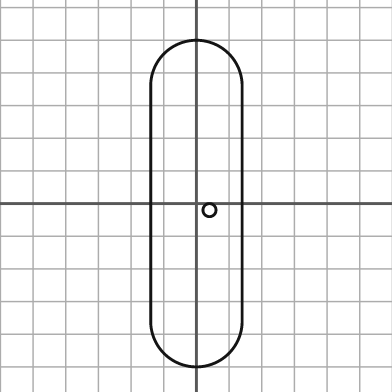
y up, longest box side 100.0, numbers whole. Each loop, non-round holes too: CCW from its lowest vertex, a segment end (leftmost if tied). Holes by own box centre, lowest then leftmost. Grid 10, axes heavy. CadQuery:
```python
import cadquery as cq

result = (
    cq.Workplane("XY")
    .moveTo(-14.0, -36.0)
    .threePointArc((0.0, -50.0), (14.0, -36.0))
    .lineTo(14.0, 36.0)
    .threePointArc((0.0, 50.0), (-14.0, 36.0))
    .close()
    .moveTo(4.0, -2.0)
    .circle(2.0)
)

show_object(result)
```